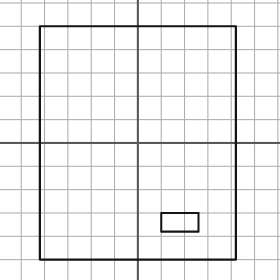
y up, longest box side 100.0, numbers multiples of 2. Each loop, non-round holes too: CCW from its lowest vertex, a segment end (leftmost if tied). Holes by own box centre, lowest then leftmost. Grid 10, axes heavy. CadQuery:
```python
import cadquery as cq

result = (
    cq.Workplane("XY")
    .moveTo(-42.0, -50.0)
    .lineTo(42.0, -50.0)
    .lineTo(42.0, 50.0)
    .lineTo(-42.0, 50.0)
    .close()
    .moveTo(10.0, -38.0)
    .lineTo(26.0, -38.0)
    .lineTo(26.0, -30.0)
    .lineTo(10.0, -30.0)
    .close()
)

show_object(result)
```